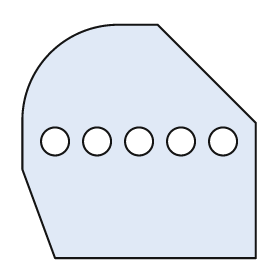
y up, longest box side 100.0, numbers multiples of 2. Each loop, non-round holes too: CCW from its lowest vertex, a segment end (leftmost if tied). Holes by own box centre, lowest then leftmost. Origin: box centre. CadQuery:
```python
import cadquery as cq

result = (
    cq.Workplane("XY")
    .moveTo(-36.0, -50.0)
    .lineTo(50.0, -50.0)
    .lineTo(50.0, 8.0)
    .lineTo(8.0, 50.0)
    .lineTo(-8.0, 50.0)
    .threePointArc((-38.0, 38.0), (-50.0, 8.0))
    .lineTo(-50.0, -12.0)
    .close()
    .moveTo(-36.0, 0.0)
    .circle(6.0)
    .moveTo(-18.0, 0.0)
    .circle(6.0)
    .moveTo(0.0, 0.0)
    .circle(6.0)
    .moveTo(18.0, 0.0)
    .circle(6.0)
    .moveTo(36.0, 0.0)
    .circle(6.0)
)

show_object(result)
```